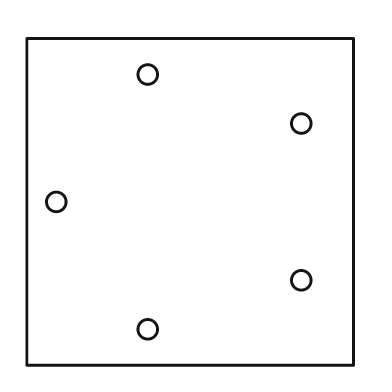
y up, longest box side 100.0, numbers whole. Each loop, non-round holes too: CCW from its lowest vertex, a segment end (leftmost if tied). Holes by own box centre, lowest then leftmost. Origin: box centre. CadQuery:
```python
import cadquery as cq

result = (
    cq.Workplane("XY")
    .moveTo(-50.0, -50.0)
    .lineTo(50.0, -50.0)
    .lineTo(50.0, 50.0)
    .lineTo(-50.0, 50.0)
    .close()
    .moveTo(-13.0, -39.0)
    .circle(3.0)
    .moveTo(34.0, -24.0)
    .circle(3.0)
    .moveTo(-41.0, 0.0)
    .circle(3.0)
    .moveTo(34.0, 24.0)
    .circle(3.0)
    .moveTo(-13.0, 39.0)
    .circle(3.0)
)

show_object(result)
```